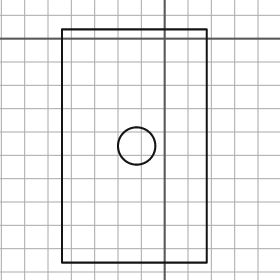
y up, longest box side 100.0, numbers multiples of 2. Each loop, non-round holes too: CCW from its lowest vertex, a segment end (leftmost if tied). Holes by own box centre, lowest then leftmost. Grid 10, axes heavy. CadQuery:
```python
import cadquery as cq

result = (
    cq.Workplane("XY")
    .moveTo(-44.0, -96.0)
    .lineTo(18.0, -96.0)
    .lineTo(18.0, 4.0)
    .lineTo(-44.0, 4.0)
    .close()
    .moveTo(-12.0, -46.0)
    .circle(8.0)
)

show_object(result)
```